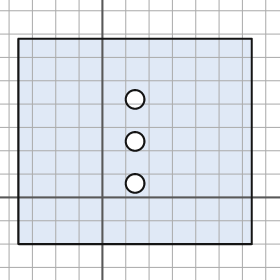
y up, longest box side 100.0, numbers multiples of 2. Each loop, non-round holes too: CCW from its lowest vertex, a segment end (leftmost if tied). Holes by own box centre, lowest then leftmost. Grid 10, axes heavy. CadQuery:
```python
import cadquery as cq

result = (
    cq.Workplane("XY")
    .moveTo(-36.0, -20.0)
    .lineTo(64.0, -20.0)
    .lineTo(64.0, 68.0)
    .lineTo(-36.0, 68.0)
    .close()
    .moveTo(14.0, 6.0)
    .circle(4.0)
    .moveTo(14.0, 24.0)
    .circle(4.0)
    .moveTo(14.0, 42.0)
    .circle(4.0)
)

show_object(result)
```